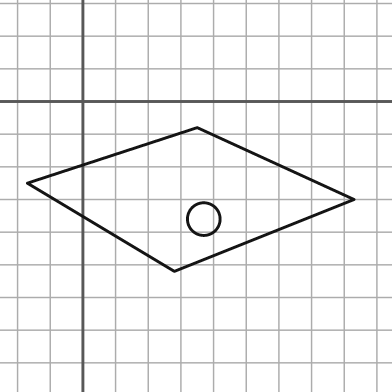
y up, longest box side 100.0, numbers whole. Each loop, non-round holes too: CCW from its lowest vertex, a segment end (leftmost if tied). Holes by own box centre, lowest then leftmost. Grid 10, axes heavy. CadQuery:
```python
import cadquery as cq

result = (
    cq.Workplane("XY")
    .moveTo(28.0, -52.0)
    .lineTo(83.0, -30.0)
    .lineTo(35.0, -8.0)
    .lineTo(-17.0, -25.0)
    .close()
    .moveTo(37.0, -36.0)
    .circle(5.0)
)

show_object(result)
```